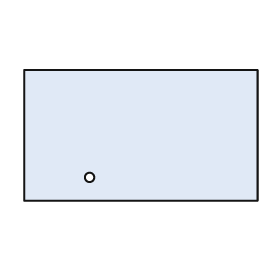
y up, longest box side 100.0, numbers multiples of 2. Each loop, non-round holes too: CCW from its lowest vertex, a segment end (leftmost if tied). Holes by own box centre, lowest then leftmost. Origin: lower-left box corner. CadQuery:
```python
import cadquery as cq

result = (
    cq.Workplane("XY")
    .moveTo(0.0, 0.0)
    .lineTo(100.0, 0.0)
    .lineTo(100.0, 56.0)
    .lineTo(0.0, 56.0)
    .close()
    .moveTo(28.0, 10.0)
    .circle(2.0)
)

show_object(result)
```